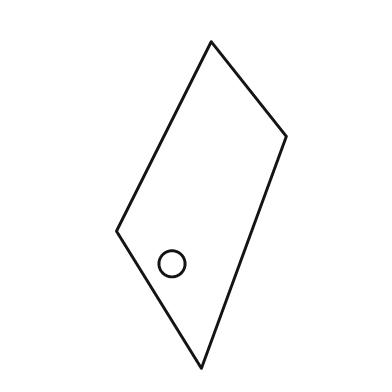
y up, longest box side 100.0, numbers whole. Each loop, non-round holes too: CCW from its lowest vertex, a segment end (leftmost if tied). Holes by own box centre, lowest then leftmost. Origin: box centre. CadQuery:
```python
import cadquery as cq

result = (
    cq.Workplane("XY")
    .moveTo(0.0, -50.0)
    .lineTo(26.0, 21.0)
    .lineTo(3.0, 50.0)
    .lineTo(-26.0, -8.0)
    .close()
    .moveTo(-9.0, -18.0)
    .circle(4.0)
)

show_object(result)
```